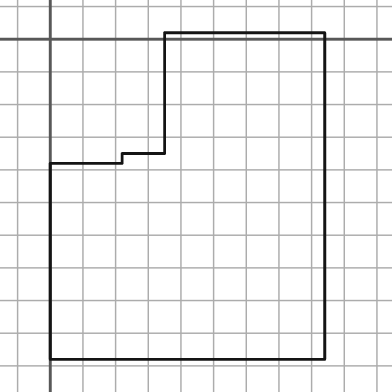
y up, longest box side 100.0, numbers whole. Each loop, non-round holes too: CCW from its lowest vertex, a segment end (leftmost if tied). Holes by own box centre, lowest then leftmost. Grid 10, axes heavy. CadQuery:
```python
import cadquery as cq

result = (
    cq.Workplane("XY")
    .moveTo(0.0, -98.0)
    .lineTo(84.0, -98.0)
    .lineTo(84.0, 2.0)
    .lineTo(35.0, 2.0)
    .lineTo(35.0, -35.0)
    .lineTo(22.0, -35.0)
    .lineTo(22.0, -38.0)
    .lineTo(0.0, -38.0)
    .close()
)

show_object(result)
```